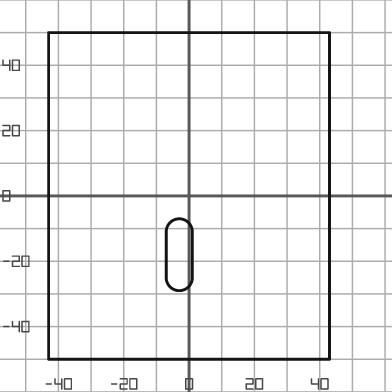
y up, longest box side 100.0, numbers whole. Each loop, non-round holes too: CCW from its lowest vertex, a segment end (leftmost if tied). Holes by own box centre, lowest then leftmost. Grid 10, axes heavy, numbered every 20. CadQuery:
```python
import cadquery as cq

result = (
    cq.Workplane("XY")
    .moveTo(-43.0, -50.0)
    .lineTo(43.0, -50.0)
    .lineTo(43.0, 50.0)
    .lineTo(-43.0, 50.0)
    .close()
    .moveTo(-7.0, -25.0)
    .threePointArc((-3.0, -29.0), (1.0, -25.0))
    .lineTo(1.0, -11.0)
    .threePointArc((-3.0, -7.0), (-7.0, -11.0))
    .close()
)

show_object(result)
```